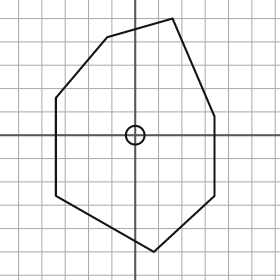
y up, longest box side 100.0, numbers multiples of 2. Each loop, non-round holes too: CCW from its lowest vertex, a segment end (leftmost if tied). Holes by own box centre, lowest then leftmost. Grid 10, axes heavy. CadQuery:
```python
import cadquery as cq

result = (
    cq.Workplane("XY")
    .moveTo(8.0, -50.0)
    .lineTo(34.0, -26.0)
    .lineTo(34.0, 8.0)
    .lineTo(16.0, 50.0)
    .lineTo(-12.0, 42.0)
    .lineTo(-34.0, 16.0)
    .lineTo(-34.0, -26.0)
    .close()
    .moveTo(0.0, 0.0)
    .circle(4.0)
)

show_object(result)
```